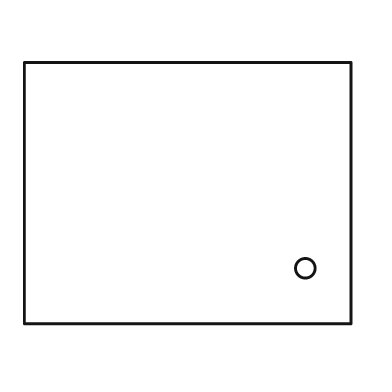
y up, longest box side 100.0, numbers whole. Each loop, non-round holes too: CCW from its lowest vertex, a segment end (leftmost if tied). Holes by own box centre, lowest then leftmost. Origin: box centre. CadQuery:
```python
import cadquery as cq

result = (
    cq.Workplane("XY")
    .moveTo(-50.0, -40.0)
    .lineTo(50.0, -40.0)
    .lineTo(50.0, 40.0)
    .lineTo(-50.0, 40.0)
    .close()
    .moveTo(36.0, -23.0)
    .circle(3.0)
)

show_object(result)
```